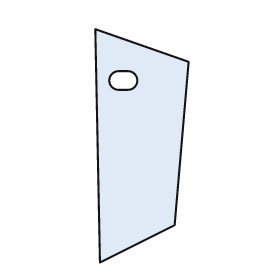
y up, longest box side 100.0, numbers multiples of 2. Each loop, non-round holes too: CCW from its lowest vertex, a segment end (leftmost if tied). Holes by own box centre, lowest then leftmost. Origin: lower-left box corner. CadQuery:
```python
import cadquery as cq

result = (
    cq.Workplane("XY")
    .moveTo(2.0, 0.0)
    .lineTo(34.0, 16.0)
    .lineTo(40.0, 86.0)
    .lineTo(0.0, 100.0)
    .close()
    .moveTo(10.0, 74.0)
    .lineTo(14.0, 74.0)
    .threePointArc((18.0, 78.0), (14.0, 82.0))
    .lineTo(10.0, 82.0)
    .threePointArc((6.0, 78.0), (10.0, 74.0))
    .close()
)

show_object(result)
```